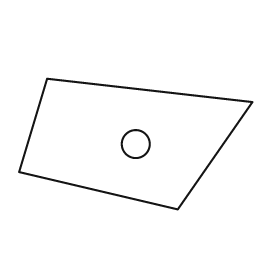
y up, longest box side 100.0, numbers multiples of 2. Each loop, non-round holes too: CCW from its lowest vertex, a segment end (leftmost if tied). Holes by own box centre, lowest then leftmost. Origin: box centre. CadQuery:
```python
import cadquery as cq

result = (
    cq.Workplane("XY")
    .moveTo(18.0, -28.0)
    .lineTo(50.0, 18.0)
    .lineTo(-38.0, 28.0)
    .lineTo(-50.0, -12.0)
    .close()
    .moveTo(0.0, 0.0)
    .circle(6.0)
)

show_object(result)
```